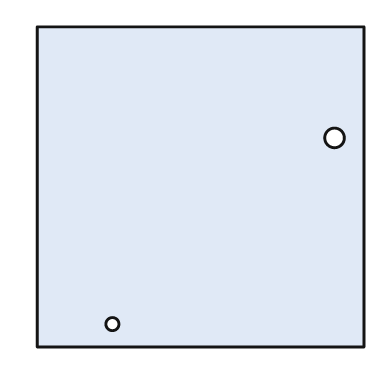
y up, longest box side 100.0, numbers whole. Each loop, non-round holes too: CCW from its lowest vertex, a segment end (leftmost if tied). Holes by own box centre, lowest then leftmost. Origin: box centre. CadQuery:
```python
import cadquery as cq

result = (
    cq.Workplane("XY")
    .moveTo(-50.0, -49.0)
    .lineTo(50.0, -49.0)
    .lineTo(50.0, 49.0)
    .lineTo(-50.0, 49.0)
    .close()
    .moveTo(-27.0, -42.0)
    .circle(2.0)
    .moveTo(41.0, 15.0)
    .circle(3.0)
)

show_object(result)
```